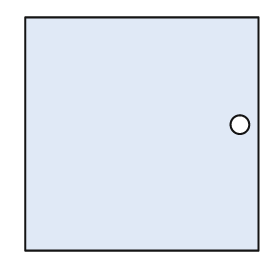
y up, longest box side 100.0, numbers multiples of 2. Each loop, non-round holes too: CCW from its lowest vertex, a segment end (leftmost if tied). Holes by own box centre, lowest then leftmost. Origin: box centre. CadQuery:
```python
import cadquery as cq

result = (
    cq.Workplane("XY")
    .moveTo(-50.0, -50.0)
    .lineTo(50.0, -50.0)
    .lineTo(50.0, 50.0)
    .lineTo(-50.0, 50.0)
    .close()
    .moveTo(42.0, 4.0)
    .circle(4.0)
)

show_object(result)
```